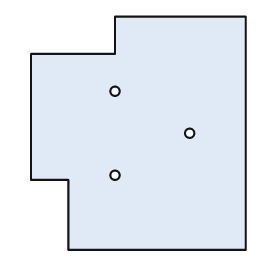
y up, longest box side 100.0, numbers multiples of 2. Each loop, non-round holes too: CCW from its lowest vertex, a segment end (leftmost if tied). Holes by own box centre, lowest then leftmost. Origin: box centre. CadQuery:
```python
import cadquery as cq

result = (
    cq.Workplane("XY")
    .moveTo(-30.0, -50.0)
    .lineTo(46.0, -50.0)
    .lineTo(46.0, 50.0)
    .lineTo(-10.0, 50.0)
    .lineTo(-10.0, 34.0)
    .lineTo(-46.0, 34.0)
    .lineTo(-46.0, -20.0)
    .lineTo(-30.0, -20.0)
    .close()
    .moveTo(-10.0, -18.0)
    .circle(2.0)
    .moveTo(22.0, 0.0)
    .circle(2.0)
    .moveTo(-10.0, 18.0)
    .circle(2.0)
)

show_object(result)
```